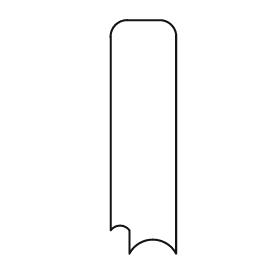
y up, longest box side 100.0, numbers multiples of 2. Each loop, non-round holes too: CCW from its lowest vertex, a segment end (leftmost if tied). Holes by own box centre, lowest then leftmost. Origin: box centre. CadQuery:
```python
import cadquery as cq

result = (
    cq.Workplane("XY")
    .moveTo(-6.0, -50.0)
    .threePointArc((4.0, -44.0), (14.0, -50.0))
    .lineTo(14.0, 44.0)
    .threePointArc((12.0, 48.0), (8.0, 50.0))
    .lineTo(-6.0, 50.0)
    .threePointArc((-12.0, 48.0), (-14.0, 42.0))
    .lineTo(-14.0, -40.0)
    .threePointArc((-10.0, -38.0), (-6.0, -40.0))
    .close()
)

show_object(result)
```